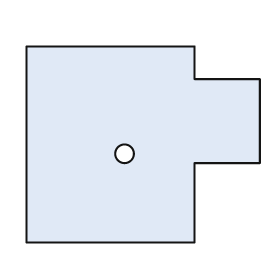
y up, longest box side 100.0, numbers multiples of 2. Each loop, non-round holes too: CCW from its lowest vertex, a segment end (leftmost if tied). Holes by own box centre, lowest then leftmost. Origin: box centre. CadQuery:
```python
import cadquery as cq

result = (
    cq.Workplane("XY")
    .moveTo(-50.0, -42.0)
    .lineTo(22.0, -42.0)
    .lineTo(22.0, -8.0)
    .lineTo(50.0, -8.0)
    .lineTo(50.0, 28.0)
    .lineTo(22.0, 28.0)
    .lineTo(22.0, 42.0)
    .lineTo(-50.0, 42.0)
    .close()
    .moveTo(-8.0, -4.0)
    .circle(4.0)
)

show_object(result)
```